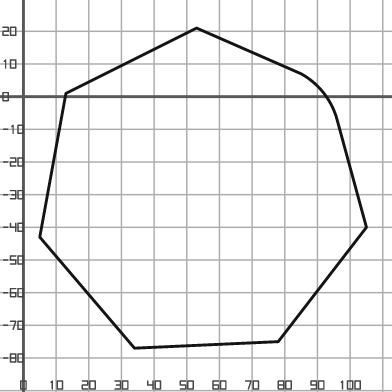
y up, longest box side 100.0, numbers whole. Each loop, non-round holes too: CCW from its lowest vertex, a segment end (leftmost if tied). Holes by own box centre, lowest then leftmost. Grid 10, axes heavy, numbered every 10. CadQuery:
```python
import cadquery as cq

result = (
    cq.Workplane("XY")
    .moveTo(34.0, -77.0)
    .lineTo(78.0, -75.0)
    .lineTo(105.0, -40.0)
    .lineTo(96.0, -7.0)
    .threePointArc((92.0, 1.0), (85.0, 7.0))
    .lineTo(53.0, 21.0)
    .lineTo(13.0, 1.0)
    .lineTo(5.0, -43.0)
    .close()
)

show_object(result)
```